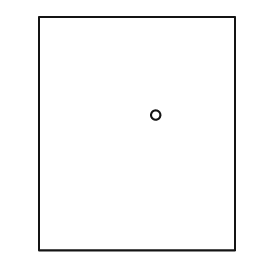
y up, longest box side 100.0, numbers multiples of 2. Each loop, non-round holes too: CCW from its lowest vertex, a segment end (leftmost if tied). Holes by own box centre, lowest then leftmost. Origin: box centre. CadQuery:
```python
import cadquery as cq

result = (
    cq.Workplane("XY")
    .moveTo(-42.0, -50.0)
    .lineTo(42.0, -50.0)
    .lineTo(42.0, 50.0)
    .lineTo(-42.0, 50.0)
    .close()
    .moveTo(8.0, 8.0)
    .circle(2.0)
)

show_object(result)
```